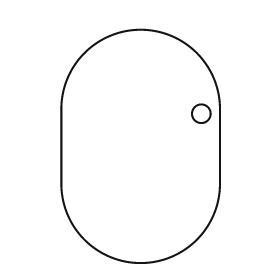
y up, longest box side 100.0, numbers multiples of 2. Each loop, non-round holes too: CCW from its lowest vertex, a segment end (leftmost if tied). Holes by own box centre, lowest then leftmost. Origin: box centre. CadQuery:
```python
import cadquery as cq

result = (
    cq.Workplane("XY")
    .moveTo(-34.0, -16.0)
    .threePointArc((0.0, -50.0), (34.0, -16.0))
    .lineTo(34.0, 16.0)
    .threePointArc((0.0, 50.0), (-34.0, 16.0))
    .close()
    .moveTo(26.0, 14.0)
    .circle(4.0)
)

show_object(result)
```